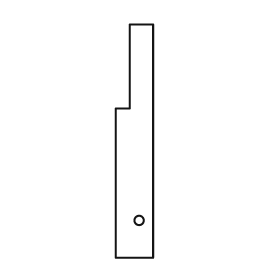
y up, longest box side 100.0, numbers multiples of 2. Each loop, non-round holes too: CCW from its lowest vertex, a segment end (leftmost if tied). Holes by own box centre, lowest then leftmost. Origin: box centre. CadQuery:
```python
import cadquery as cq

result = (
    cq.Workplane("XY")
    .moveTo(-8.0, -50.0)
    .lineTo(8.0, -50.0)
    .lineTo(8.0, 50.0)
    .lineTo(-2.0, 50.0)
    .lineTo(-2.0, 14.0)
    .lineTo(-8.0, 14.0)
    .close()
    .moveTo(2.0, -34.0)
    .circle(2.0)
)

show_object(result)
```